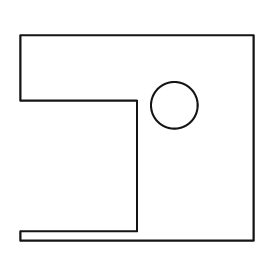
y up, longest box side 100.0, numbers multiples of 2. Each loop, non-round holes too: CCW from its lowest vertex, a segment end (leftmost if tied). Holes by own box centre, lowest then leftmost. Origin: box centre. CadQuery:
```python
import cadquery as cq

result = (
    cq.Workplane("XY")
    .moveTo(-50.0, -44.0)
    .lineTo(50.0, -44.0)
    .lineTo(50.0, 44.0)
    .lineTo(-50.0, 44.0)
    .lineTo(-50.0, 16.0)
    .lineTo(0.0, 16.0)
    .lineTo(0.0, -40.0)
    .lineTo(-50.0, -40.0)
    .close()
    .moveTo(16.0, 14.0)
    .circle(10.0)
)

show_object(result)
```